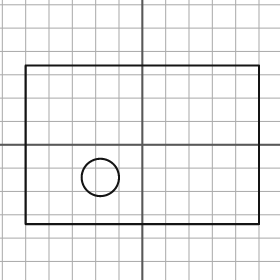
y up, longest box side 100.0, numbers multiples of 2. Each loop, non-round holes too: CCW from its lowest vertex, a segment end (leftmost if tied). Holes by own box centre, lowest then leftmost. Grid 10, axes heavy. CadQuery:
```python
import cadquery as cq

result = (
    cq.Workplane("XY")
    .moveTo(-50.0, -34.0)
    .lineTo(50.0, -34.0)
    .lineTo(50.0, 34.0)
    .lineTo(-50.0, 34.0)
    .close()
    .moveTo(-18.0, -14.0)
    .circle(8.0)
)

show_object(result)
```